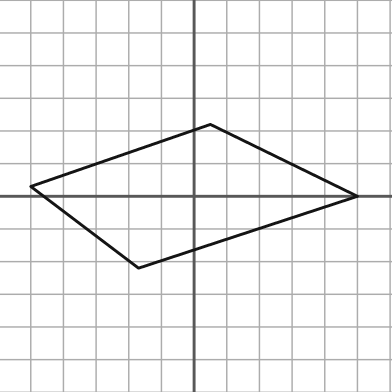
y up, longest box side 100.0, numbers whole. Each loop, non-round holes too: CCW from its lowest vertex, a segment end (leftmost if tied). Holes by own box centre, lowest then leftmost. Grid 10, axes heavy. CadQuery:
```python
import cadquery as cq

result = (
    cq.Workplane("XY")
    .moveTo(-17.0, -22.0)
    .lineTo(50.0, 0.0)
    .lineTo(5.0, 22.0)
    .lineTo(-50.0, 3.0)
    .close()
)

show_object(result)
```